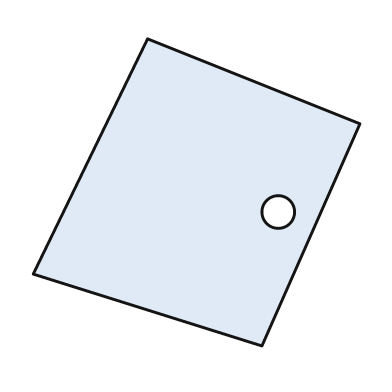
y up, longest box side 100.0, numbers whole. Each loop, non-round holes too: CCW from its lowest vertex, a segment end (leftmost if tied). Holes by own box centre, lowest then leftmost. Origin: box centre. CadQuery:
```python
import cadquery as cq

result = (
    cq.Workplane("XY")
    .moveTo(20.0, -47.0)
    .lineTo(50.0, 21.0)
    .lineTo(-15.0, 47.0)
    .lineTo(-50.0, -25.0)
    .close()
    .moveTo(25.0, -6.0)
    .circle(5.0)
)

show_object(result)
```